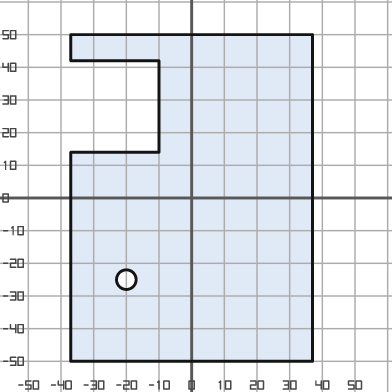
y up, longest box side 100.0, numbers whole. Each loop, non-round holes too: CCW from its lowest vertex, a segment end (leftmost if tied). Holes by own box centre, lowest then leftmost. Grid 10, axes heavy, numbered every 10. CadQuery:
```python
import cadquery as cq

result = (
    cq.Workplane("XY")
    .moveTo(-37.0, -50.0)
    .lineTo(37.0, -50.0)
    .lineTo(37.0, 50.0)
    .lineTo(-37.0, 50.0)
    .lineTo(-37.0, 42.0)
    .lineTo(-10.0, 42.0)
    .lineTo(-10.0, 14.0)
    .lineTo(-37.0, 14.0)
    .close()
    .moveTo(-20.0, -25.0)
    .circle(3.0)
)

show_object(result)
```